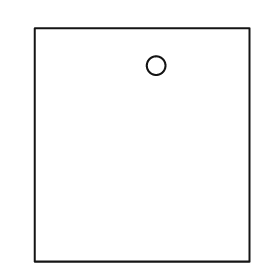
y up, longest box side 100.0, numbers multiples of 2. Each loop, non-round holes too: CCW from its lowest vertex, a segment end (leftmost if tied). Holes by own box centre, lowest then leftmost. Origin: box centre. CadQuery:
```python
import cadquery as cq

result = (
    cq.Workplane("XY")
    .moveTo(-46.0, -50.0)
    .lineTo(46.0, -50.0)
    .lineTo(46.0, 50.0)
    .lineTo(-46.0, 50.0)
    .close()
    .moveTo(6.0, 34.0)
    .circle(4.0)
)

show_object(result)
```